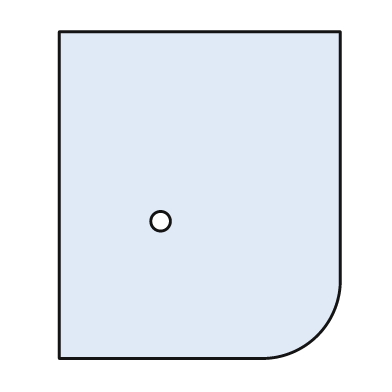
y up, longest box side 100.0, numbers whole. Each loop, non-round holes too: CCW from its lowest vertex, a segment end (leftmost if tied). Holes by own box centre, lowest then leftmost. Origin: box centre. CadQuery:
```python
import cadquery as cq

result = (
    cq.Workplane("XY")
    .moveTo(-43.0, -50.0)
    .lineTo(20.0, -50.0)
    .threePointArc((36.0, -43.0), (43.0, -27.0))
    .lineTo(43.0, 50.0)
    .lineTo(-43.0, 50.0)
    .close()
    .moveTo(-12.0, -8.0)
    .circle(3.0)
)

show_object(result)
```